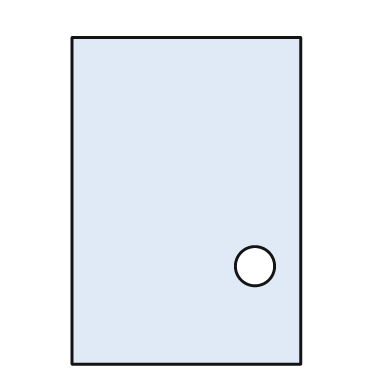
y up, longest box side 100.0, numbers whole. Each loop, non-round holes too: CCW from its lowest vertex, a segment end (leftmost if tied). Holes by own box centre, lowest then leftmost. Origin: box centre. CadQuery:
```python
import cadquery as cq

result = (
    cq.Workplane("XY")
    .moveTo(-35.0, -50.0)
    .lineTo(35.0, -50.0)
    .lineTo(35.0, 50.0)
    .lineTo(-35.0, 50.0)
    .close()
    .moveTo(21.0, -20.0)
    .circle(6.0)
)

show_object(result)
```